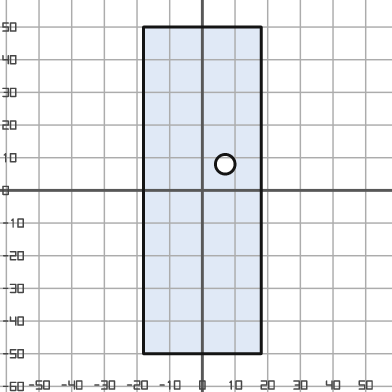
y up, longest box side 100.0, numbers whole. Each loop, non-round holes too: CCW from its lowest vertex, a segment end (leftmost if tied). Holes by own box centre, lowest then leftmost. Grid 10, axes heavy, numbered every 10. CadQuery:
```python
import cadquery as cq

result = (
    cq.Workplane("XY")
    .moveTo(-18.0, -50.0)
    .lineTo(18.0, -50.0)
    .lineTo(18.0, 50.0)
    .lineTo(-18.0, 50.0)
    .close()
    .moveTo(7.0, 8.0)
    .circle(3.0)
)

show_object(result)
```